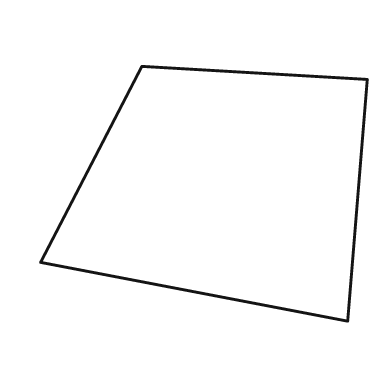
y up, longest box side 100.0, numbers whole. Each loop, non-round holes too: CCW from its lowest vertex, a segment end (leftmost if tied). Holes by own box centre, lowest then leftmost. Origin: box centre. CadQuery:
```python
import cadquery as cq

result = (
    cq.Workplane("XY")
    .moveTo(44.0, -39.0)
    .lineTo(50.0, 35.0)
    .lineTo(-19.0, 39.0)
    .lineTo(-50.0, -21.0)
    .close()
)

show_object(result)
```